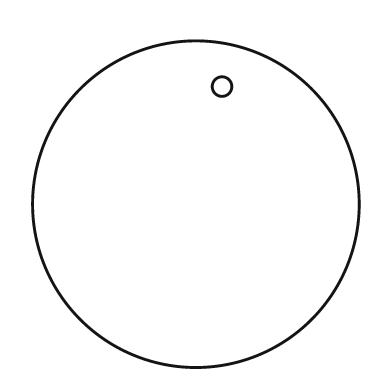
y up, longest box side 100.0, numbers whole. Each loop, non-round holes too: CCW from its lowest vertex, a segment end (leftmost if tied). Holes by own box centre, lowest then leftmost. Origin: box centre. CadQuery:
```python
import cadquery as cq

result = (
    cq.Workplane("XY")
    .moveTo(0.0, 0.0)
    .circle(50.0)
    .moveTo(8.0, 36.0)
    .circle(3.0)
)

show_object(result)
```